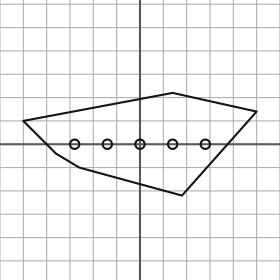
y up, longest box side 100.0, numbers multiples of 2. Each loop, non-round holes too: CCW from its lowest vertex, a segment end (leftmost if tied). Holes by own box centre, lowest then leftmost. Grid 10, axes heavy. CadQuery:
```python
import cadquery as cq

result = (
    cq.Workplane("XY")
    .moveTo(18.0, -22.0)
    .lineTo(50.0, 14.0)
    .lineTo(14.0, 22.0)
    .lineTo(-50.0, 10.0)
    .lineTo(-36.0, -4.0)
    .lineTo(-26.0, -10.0)
    .close()
    .moveTo(-28.0, 0.0)
    .circle(2.0)
    .moveTo(-14.0, 0.0)
    .circle(2.0)
    .moveTo(0.0, 0.0)
    .circle(2.0)
    .moveTo(14.0, 0.0)
    .circle(2.0)
    .moveTo(28.0, 0.0)
    .circle(2.0)
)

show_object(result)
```